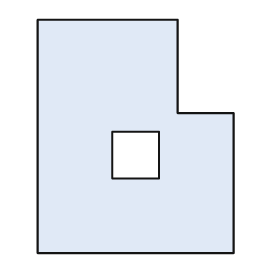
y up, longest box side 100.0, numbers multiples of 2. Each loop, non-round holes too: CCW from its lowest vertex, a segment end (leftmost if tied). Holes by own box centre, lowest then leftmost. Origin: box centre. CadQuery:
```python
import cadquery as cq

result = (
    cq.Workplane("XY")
    .moveTo(-42.0, -50.0)
    .lineTo(42.0, -50.0)
    .lineTo(42.0, 10.0)
    .lineTo(18.0, 10.0)
    .lineTo(18.0, 50.0)
    .lineTo(-42.0, 50.0)
    .close()
    .moveTo(-10.0, -18.0)
    .lineTo(10.0, -18.0)
    .lineTo(10.0, 2.0)
    .lineTo(-10.0, 2.0)
    .close()
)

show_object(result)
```